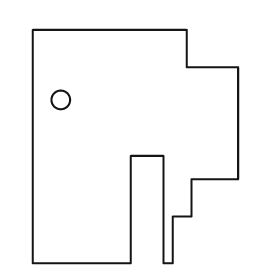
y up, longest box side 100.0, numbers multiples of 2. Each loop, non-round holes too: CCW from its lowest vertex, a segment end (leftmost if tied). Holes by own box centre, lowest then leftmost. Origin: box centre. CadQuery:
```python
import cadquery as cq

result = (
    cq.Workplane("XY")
    .moveTo(-44.0, -50.0)
    .lineTo(-2.0, -50.0)
    .lineTo(-2.0, -4.0)
    .lineTo(12.0, -4.0)
    .lineTo(12.0, -50.0)
    .lineTo(16.0, -50.0)
    .lineTo(16.0, -30.0)
    .lineTo(24.0, -30.0)
    .lineTo(24.0, -14.0)
    .lineTo(44.0, -14.0)
    .lineTo(44.0, 34.0)
    .lineTo(22.0, 34.0)
    .lineTo(22.0, 50.0)
    .lineTo(-44.0, 50.0)
    .close()
    .moveTo(-32.0, 20.0)
    .circle(4.0)
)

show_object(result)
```